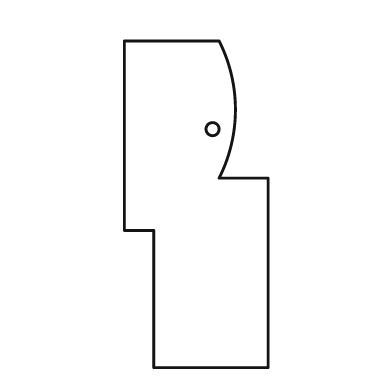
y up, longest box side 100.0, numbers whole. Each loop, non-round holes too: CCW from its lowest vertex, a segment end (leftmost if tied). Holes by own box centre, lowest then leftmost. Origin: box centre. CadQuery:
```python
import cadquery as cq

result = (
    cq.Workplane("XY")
    .moveTo(-13.0, -50.0)
    .lineTo(22.0, -50.0)
    .lineTo(22.0, 8.0)
    .lineTo(7.0, 8.0)
    .threePointArc((12.0, 29.0), (7.0, 50.0))
    .lineTo(-22.0, 50.0)
    .lineTo(-22.0, -8.0)
    .lineTo(-13.0, -8.0)
    .close()
    .moveTo(5.0, 23.0)
    .circle(2.0)
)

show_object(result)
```